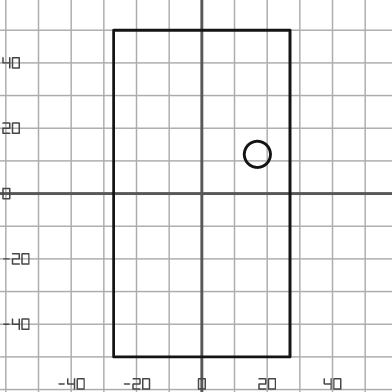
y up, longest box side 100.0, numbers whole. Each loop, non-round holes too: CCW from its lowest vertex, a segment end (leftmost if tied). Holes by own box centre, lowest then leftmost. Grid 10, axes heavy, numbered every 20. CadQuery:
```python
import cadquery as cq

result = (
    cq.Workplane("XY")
    .moveTo(-27.0, -50.0)
    .lineTo(27.0, -50.0)
    .lineTo(27.0, 50.0)
    .lineTo(-27.0, 50.0)
    .close()
    .moveTo(17.0, 12.0)
    .circle(4.0)
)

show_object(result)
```